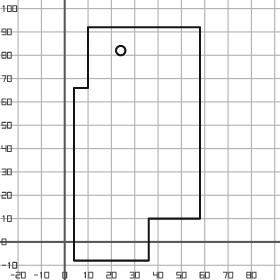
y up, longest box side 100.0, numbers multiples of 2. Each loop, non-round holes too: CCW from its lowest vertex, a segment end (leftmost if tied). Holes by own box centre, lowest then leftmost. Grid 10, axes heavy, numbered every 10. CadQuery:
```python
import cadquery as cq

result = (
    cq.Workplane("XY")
    .moveTo(4.0, -8.0)
    .lineTo(36.0, -8.0)
    .lineTo(36.0, 10.0)
    .lineTo(58.0, 10.0)
    .lineTo(58.0, 92.0)
    .lineTo(10.0, 92.0)
    .lineTo(10.0, 66.0)
    .lineTo(4.0, 66.0)
    .close()
    .moveTo(24.0, 82.0)
    .circle(2.0)
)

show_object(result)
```